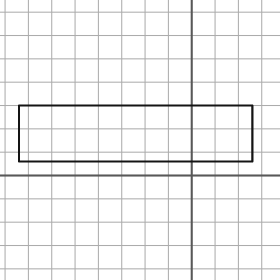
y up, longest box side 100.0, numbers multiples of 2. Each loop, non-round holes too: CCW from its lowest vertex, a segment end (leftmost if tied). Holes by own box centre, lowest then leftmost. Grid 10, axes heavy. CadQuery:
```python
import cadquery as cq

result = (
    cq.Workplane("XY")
    .moveTo(-74.0, 6.0)
    .lineTo(26.0, 6.0)
    .lineTo(26.0, 30.0)
    .lineTo(-74.0, 30.0)
    .close()
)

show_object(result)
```